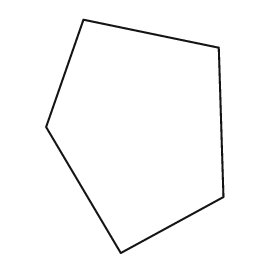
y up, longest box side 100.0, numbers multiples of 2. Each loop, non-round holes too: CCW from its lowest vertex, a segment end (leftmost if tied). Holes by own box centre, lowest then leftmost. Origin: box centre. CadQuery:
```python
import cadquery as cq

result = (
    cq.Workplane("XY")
    .moveTo(-6.0, -50.0)
    .lineTo(38.0, -26.0)
    .lineTo(36.0, 38.0)
    .lineTo(-22.0, 50.0)
    .lineTo(-38.0, 4.0)
    .close()
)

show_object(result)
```